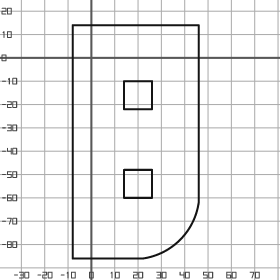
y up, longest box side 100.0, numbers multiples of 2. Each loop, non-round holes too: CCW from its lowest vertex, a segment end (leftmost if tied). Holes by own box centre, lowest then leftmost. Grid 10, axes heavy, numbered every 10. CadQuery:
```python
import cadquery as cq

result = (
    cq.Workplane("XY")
    .moveTo(-8.0, -86.0)
    .lineTo(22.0, -86.0)
    .threePointArc((38.0, -78.0), (46.0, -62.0))
    .lineTo(46.0, 14.0)
    .lineTo(-8.0, 14.0)
    .close()
    .moveTo(14.0, -60.0)
    .lineTo(26.0, -60.0)
    .lineTo(26.0, -48.0)
    .lineTo(14.0, -48.0)
    .close()
    .moveTo(14.0, -22.0)
    .lineTo(26.0, -22.0)
    .lineTo(26.0, -10.0)
    .lineTo(14.0, -10.0)
    .close()
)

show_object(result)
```